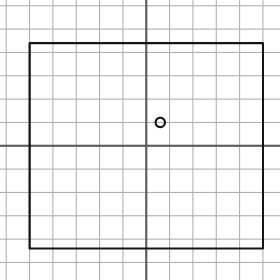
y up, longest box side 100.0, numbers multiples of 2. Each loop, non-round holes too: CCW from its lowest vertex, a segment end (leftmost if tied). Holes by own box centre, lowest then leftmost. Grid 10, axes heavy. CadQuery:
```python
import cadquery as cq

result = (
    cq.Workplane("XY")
    .moveTo(-50.0, -44.0)
    .lineTo(50.0, -44.0)
    .lineTo(50.0, 44.0)
    .lineTo(-50.0, 44.0)
    .close()
    .moveTo(6.0, 10.0)
    .circle(2.0)
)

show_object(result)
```